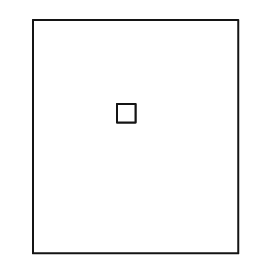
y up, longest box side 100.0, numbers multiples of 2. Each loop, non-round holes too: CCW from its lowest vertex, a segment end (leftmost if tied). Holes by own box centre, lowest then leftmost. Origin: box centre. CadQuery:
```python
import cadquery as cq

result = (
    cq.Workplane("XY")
    .moveTo(-44.0, -50.0)
    .lineTo(44.0, -50.0)
    .lineTo(44.0, 50.0)
    .lineTo(-44.0, 50.0)
    .close()
    .moveTo(-8.0, 6.0)
    .lineTo(0.0, 6.0)
    .lineTo(0.0, 14.0)
    .lineTo(-8.0, 14.0)
    .close()
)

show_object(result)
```